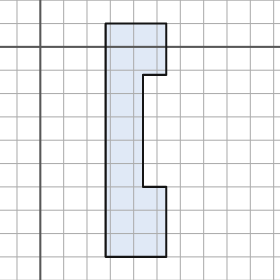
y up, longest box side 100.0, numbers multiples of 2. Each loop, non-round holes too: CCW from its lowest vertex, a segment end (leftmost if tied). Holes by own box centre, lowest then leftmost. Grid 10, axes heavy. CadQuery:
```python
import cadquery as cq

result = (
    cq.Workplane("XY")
    .moveTo(28.0, -90.0)
    .lineTo(54.0, -90.0)
    .lineTo(54.0, -60.0)
    .lineTo(44.0, -60.0)
    .lineTo(44.0, -12.0)
    .lineTo(54.0, -12.0)
    .lineTo(54.0, 10.0)
    .lineTo(28.0, 10.0)
    .close()
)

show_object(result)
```